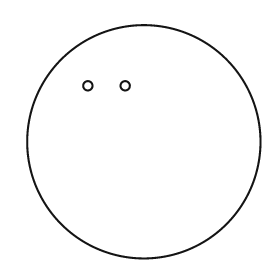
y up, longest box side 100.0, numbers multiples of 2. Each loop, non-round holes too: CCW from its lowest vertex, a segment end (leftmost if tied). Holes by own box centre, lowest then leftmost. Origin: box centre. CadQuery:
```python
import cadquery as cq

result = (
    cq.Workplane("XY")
    .moveTo(0.0, 0.0)
    .circle(50.0)
    .moveTo(-24.0, 24.0)
    .circle(2.0)
    .moveTo(-8.0, 24.0)
    .circle(2.0)
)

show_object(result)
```